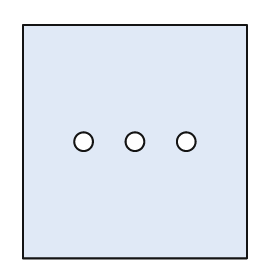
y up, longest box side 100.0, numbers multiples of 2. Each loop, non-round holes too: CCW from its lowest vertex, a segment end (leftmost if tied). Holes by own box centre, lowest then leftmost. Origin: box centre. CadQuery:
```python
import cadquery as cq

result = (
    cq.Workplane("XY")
    .moveTo(-48.0, -50.0)
    .lineTo(48.0, -50.0)
    .lineTo(48.0, 50.0)
    .lineTo(-48.0, 50.0)
    .close()
    .moveTo(-22.0, 0.0)
    .circle(4.0)
    .moveTo(0.0, 0.0)
    .circle(4.0)
    .moveTo(22.0, 0.0)
    .circle(4.0)
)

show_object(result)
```